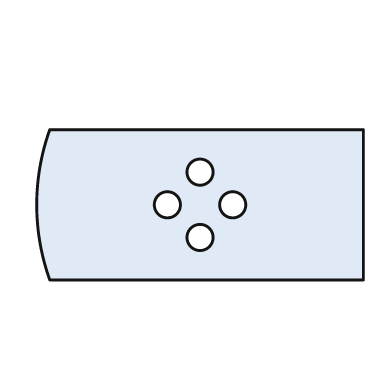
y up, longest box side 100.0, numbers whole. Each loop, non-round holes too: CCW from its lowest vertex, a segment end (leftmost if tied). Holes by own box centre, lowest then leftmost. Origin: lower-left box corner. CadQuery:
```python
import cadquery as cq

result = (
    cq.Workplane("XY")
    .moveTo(4.0, 0.0)
    .lineTo(100.0, 0.0)
    .lineTo(100.0, 46.0)
    .lineTo(4.0, 46.0)
    .threePointArc((0.0, 23.0), (4.0, 0.0))
    .close()
    .moveTo(50.0, 13.0)
    .circle(4.0)
    .moveTo(40.0, 23.0)
    .circle(4.0)
    .moveTo(60.0, 23.0)
    .circle(4.0)
    .moveTo(50.0, 33.0)
    .circle(4.0)
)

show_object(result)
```